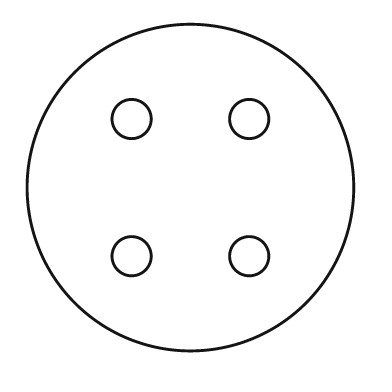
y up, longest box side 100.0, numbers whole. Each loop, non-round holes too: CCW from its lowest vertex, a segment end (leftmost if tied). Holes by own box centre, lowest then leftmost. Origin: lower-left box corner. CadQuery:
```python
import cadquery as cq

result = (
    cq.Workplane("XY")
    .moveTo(50.0, 50.0)
    .circle(50.0)
    .moveTo(32.0, 29.0)
    .circle(6.0)
    .moveTo(68.0, 29.0)
    .circle(6.0)
    .moveTo(32.0, 71.0)
    .circle(6.0)
    .moveTo(68.0, 71.0)
    .circle(6.0)
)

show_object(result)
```